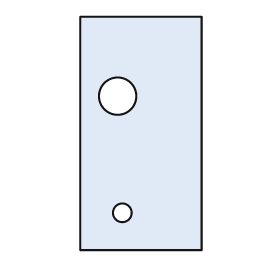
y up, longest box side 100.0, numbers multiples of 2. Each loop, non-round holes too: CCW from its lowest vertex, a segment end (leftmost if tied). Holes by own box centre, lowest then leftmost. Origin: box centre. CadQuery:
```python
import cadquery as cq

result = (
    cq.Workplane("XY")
    .moveTo(-26.0, -50.0)
    .lineTo(26.0, -50.0)
    .lineTo(26.0, 50.0)
    .lineTo(-26.0, 50.0)
    .close()
    .moveTo(-8.0, -34.0)
    .circle(4.0)
    .moveTo(-10.0, 16.0)
    .circle(8.0)
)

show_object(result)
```